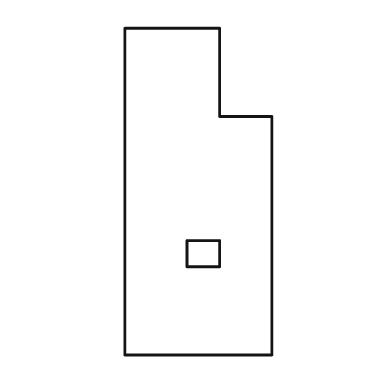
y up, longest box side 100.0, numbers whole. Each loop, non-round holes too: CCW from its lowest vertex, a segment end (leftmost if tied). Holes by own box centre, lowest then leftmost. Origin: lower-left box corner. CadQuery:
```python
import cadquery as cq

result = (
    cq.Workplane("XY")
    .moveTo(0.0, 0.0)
    .lineTo(45.0, 0.0)
    .lineTo(45.0, 73.0)
    .lineTo(29.0, 73.0)
    .lineTo(29.0, 100.0)
    .lineTo(0.0, 100.0)
    .close()
    .moveTo(19.0, 27.0)
    .lineTo(29.0, 27.0)
    .lineTo(29.0, 35.0)
    .lineTo(19.0, 35.0)
    .close()
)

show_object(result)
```